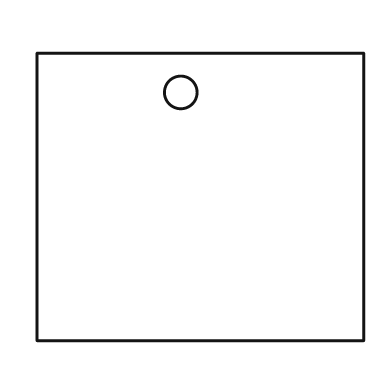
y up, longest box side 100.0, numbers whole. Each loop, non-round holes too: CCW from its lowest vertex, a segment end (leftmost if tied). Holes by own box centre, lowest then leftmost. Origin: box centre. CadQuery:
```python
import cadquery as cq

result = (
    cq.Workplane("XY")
    .moveTo(-50.0, -44.0)
    .lineTo(50.0, -44.0)
    .lineTo(50.0, 44.0)
    .lineTo(-50.0, 44.0)
    .close()
    .moveTo(-6.0, 32.0)
    .circle(5.0)
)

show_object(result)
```